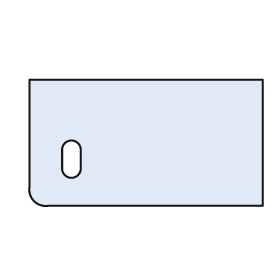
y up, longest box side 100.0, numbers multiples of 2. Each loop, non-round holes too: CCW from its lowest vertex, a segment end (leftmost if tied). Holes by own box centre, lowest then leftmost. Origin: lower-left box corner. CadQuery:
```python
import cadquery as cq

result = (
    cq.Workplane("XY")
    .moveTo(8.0, 0.0)
    .lineTo(100.0, 0.0)
    .lineTo(100.0, 54.0)
    .lineTo(0.0, 54.0)
    .lineTo(0.0, 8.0)
    .threePointArc((2.0, 2.0), (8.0, 0.0))
    .close()
    .moveTo(14.0, 16.0)
    .threePointArc((18.0, 12.0), (22.0, 16.0))
    .lineTo(22.0, 24.0)
    .threePointArc((18.0, 28.0), (14.0, 24.0))
    .close()
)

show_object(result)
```